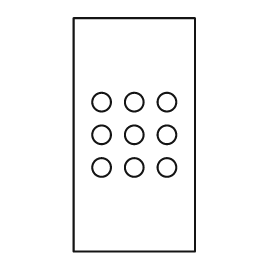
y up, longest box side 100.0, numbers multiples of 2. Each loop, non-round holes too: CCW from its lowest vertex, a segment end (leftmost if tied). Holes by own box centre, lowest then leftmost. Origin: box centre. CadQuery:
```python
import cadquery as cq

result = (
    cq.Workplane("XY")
    .moveTo(-26.0, -50.0)
    .lineTo(26.0, -50.0)
    .lineTo(26.0, 50.0)
    .lineTo(-26.0, 50.0)
    .close()
    .moveTo(-14.0, -14.0)
    .circle(4.0)
    .moveTo(0.0, -14.0)
    .circle(4.0)
    .moveTo(14.0, -14.0)
    .circle(4.0)
    .moveTo(-14.0, 0.0)
    .circle(4.0)
    .moveTo(0.0, 0.0)
    .circle(4.0)
    .moveTo(14.0, 0.0)
    .circle(4.0)
    .moveTo(-14.0, 14.0)
    .circle(4.0)
    .moveTo(0.0, 14.0)
    .circle(4.0)
    .moveTo(14.0, 14.0)
    .circle(4.0)
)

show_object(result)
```